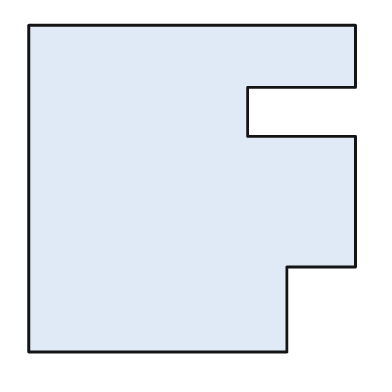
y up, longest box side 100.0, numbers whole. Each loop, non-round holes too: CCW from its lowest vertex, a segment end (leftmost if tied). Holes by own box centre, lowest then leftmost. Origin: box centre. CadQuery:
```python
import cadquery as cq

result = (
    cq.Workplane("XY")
    .moveTo(-50.0, -50.0)
    .lineTo(29.0, -50.0)
    .lineTo(29.0, -24.0)
    .lineTo(50.0, -24.0)
    .lineTo(50.0, 16.0)
    .lineTo(17.0, 16.0)
    .lineTo(17.0, 31.0)
    .lineTo(50.0, 31.0)
    .lineTo(50.0, 50.0)
    .lineTo(-50.0, 50.0)
    .close()
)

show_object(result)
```